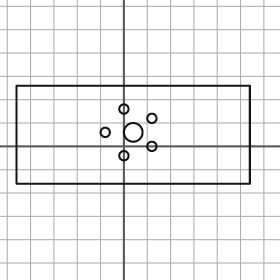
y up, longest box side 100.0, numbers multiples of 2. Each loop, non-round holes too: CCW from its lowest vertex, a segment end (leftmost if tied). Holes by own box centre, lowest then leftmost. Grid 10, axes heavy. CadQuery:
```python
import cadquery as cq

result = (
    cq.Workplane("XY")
    .moveTo(-46.0, -16.0)
    .lineTo(54.0, -16.0)
    .lineTo(54.0, 26.0)
    .lineTo(-46.0, 26.0)
    .close()
    .moveTo(0.0, -4.0)
    .circle(2.0)
    .moveTo(12.0, 0.0)
    .circle(2.0)
    .moveTo(-8.0, 6.0)
    .circle(2.0)
    .moveTo(4.0, 6.0)
    .circle(4.0)
    .moveTo(12.0, 12.0)
    .circle(2.0)
    .moveTo(0.0, 16.0)
    .circle(2.0)
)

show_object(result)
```